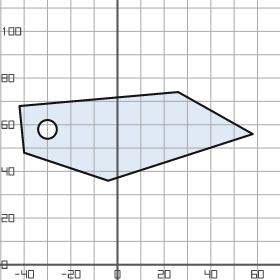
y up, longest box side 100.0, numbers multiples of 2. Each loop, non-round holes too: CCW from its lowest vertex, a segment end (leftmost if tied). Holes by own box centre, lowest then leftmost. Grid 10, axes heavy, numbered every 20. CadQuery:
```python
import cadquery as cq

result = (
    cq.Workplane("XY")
    .moveTo(-4.0, 36.0)
    .lineTo(58.0, 56.0)
    .lineTo(26.0, 74.0)
    .lineTo(-42.0, 68.0)
    .lineTo(-40.0, 48.0)
    .close()
    .moveTo(-30.0, 58.0)
    .circle(4.0)
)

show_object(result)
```